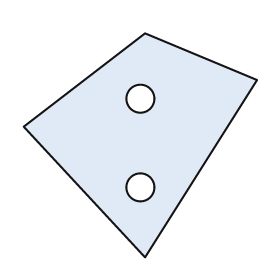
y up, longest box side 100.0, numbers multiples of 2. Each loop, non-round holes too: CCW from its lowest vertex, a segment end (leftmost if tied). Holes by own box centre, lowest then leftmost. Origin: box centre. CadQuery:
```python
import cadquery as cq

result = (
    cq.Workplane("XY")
    .moveTo(2.0, -48.0)
    .lineTo(50.0, 28.0)
    .lineTo(2.0, 48.0)
    .lineTo(-50.0, 8.0)
    .close()
    .moveTo(0.0, -18.0)
    .circle(6.0)
    .moveTo(0.0, 20.0)
    .circle(6.0)
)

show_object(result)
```